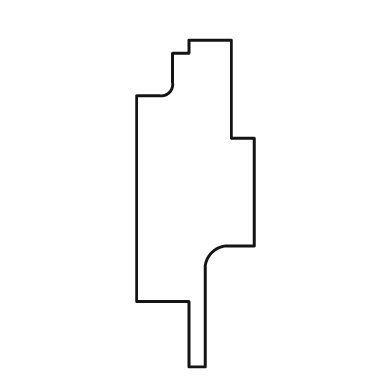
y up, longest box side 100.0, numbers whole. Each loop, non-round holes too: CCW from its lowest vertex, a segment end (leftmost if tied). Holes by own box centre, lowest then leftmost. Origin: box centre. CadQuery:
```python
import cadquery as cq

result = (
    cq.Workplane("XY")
    .moveTo(-2.0, -50.0)
    .lineTo(3.0, -50.0)
    .lineTo(3.0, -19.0)
    .threePointArc((5.0, -15.0), (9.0, -13.0))
    .lineTo(18.0, -13.0)
    .lineTo(18.0, 20.0)
    .lineTo(11.0, 20.0)
    .lineTo(11.0, 50.0)
    .lineTo(-2.0, 50.0)
    .lineTo(-2.0, 46.0)
    .lineTo(-7.0, 46.0)
    .lineTo(-7.0, 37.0)
    .threePointArc((-8.0, 34.0), (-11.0, 33.0))
    .lineTo(-18.0, 33.0)
    .lineTo(-18.0, -30.0)
    .lineTo(-2.0, -30.0)
    .close()
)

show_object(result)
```